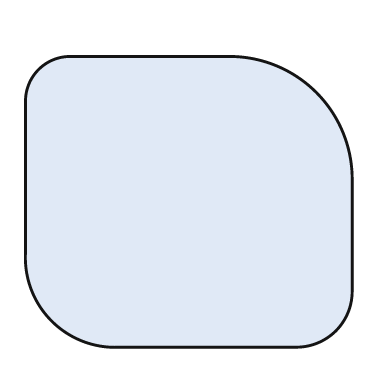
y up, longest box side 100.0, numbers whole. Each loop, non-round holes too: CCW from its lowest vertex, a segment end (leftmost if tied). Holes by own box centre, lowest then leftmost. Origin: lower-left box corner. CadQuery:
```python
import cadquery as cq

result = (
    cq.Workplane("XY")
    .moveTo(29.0, 0.0)
    .lineTo(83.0, 0.0)
    .threePointArc((95.0, 5.0), (100.0, 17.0))
    .lineTo(100.0, 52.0)
    .threePointArc((89.0, 78.0), (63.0, 89.0))
    .lineTo(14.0, 89.0)
    .threePointArc((4.0, 85.0), (0.0, 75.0))
    .lineTo(0.0, 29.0)
    .threePointArc((8.0, 8.0), (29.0, 0.0))
    .close()
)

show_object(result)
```